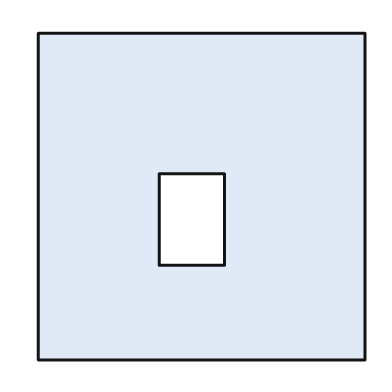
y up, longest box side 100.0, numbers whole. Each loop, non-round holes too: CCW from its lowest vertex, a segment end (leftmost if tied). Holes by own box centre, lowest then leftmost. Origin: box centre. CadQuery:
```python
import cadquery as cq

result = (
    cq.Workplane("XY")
    .moveTo(-50.0, -50.0)
    .lineTo(50.0, -50.0)
    .lineTo(50.0, 50.0)
    .lineTo(-50.0, 50.0)
    .close()
    .moveTo(-13.0, -21.0)
    .lineTo(7.0, -21.0)
    .lineTo(7.0, 7.0)
    .lineTo(-13.0, 7.0)
    .close()
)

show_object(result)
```